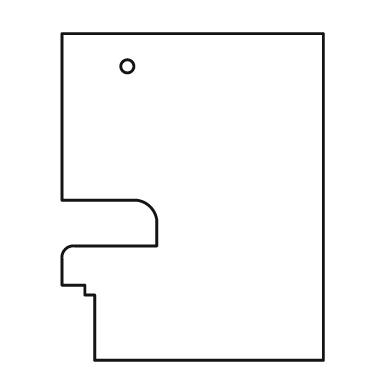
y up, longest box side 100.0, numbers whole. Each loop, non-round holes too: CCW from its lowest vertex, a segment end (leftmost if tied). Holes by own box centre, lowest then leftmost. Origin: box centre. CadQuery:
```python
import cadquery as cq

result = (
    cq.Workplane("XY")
    .moveTo(-30.0, -50.0)
    .lineTo(40.0, -50.0)
    .lineTo(40.0, 50.0)
    .lineTo(-40.0, 50.0)
    .lineTo(-40.0, -1.0)
    .lineTo(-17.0, -1.0)
    .threePointArc((-13.0, -3.0), (-11.0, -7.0))
    .lineTo(-11.0, -15.0)
    .lineTo(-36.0, -15.0)
    .threePointArc((-39.0, -16.0), (-40.0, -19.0))
    .lineTo(-40.0, -27.0)
    .lineTo(-33.0, -27.0)
    .lineTo(-33.0, -30.0)
    .lineTo(-30.0, -30.0)
    .close()
    .moveTo(-20.0, 40.0)
    .circle(2.0)
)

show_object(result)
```